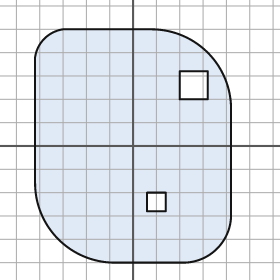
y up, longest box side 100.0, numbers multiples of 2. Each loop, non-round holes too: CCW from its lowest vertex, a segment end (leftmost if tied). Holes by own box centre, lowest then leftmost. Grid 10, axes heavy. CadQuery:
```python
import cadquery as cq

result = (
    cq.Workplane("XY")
    .moveTo(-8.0, -50.0)
    .lineTo(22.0, -50.0)
    .threePointArc((36.0, -44.0), (42.0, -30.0))
    .lineTo(42.0, 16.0)
    .threePointArc((32.0, 40.0), (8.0, 50.0))
    .lineTo(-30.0, 50.0)
    .threePointArc((-38.0, 46.0), (-42.0, 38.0))
    .lineTo(-42.0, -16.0)
    .threePointArc((-32.0, -40.0), (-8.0, -50.0))
    .close()
    .moveTo(6.0, -28.0)
    .lineTo(14.0, -28.0)
    .lineTo(14.0, -20.0)
    .lineTo(6.0, -20.0)
    .close()
    .moveTo(20.0, 20.0)
    .lineTo(32.0, 20.0)
    .lineTo(32.0, 32.0)
    .lineTo(20.0, 32.0)
    .close()
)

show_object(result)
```